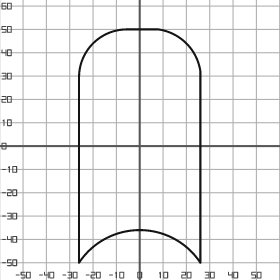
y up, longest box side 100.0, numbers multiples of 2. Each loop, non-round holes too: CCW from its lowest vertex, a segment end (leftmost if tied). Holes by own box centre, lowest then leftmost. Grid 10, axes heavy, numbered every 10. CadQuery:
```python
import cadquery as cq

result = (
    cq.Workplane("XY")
    .moveTo(-26.0, -50.0)
    .threePointArc((0.0, -36.0), (26.0, -50.0))
    .lineTo(26.0, 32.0)
    .threePointArc((20.0, 44.0), (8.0, 50.0))
    .lineTo(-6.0, 50.0)
    .threePointArc((-20.0, 44.0), (-26.0, 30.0))
    .close()
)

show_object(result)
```